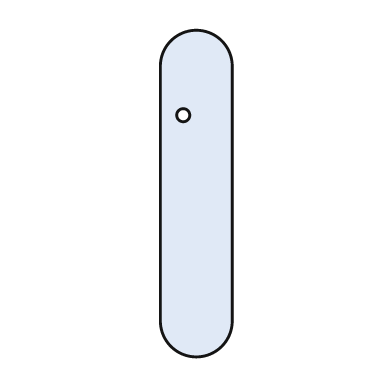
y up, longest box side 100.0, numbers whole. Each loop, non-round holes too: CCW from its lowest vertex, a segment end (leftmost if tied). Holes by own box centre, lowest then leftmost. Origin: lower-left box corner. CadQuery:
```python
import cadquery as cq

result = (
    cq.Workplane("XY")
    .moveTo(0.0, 11.0)
    .threePointArc((11.0, 0.0), (22.0, 11.0))
    .lineTo(22.0, 89.0)
    .threePointArc((11.0, 100.0), (0.0, 89.0))
    .close()
    .moveTo(7.0, 74.0)
    .circle(2.0)
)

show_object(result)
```